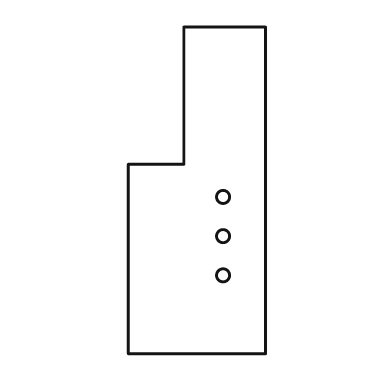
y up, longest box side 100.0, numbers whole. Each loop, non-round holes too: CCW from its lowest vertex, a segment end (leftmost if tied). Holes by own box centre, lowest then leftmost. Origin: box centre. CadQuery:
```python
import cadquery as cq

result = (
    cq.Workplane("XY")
    .moveTo(-21.0, -50.0)
    .lineTo(21.0, -50.0)
    .lineTo(21.0, 50.0)
    .lineTo(-4.0, 50.0)
    .lineTo(-4.0, 8.0)
    .lineTo(-21.0, 8.0)
    .close()
    .moveTo(8.0, -26.0)
    .circle(2.0)
    .moveTo(8.0, -14.0)
    .circle(2.0)
    .moveTo(8.0, -2.0)
    .circle(2.0)
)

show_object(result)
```